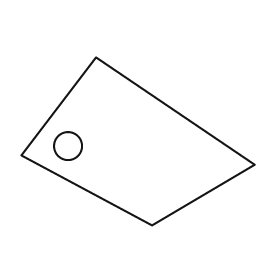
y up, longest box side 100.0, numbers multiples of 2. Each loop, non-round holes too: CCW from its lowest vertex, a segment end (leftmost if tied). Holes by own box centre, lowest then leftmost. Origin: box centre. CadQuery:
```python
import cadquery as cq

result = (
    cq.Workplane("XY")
    .moveTo(6.0, -36.0)
    .lineTo(50.0, -10.0)
    .lineTo(-18.0, 36.0)
    .lineTo(-50.0, -6.0)
    .close()
    .moveTo(-30.0, -2.0)
    .circle(6.0)
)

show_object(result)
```